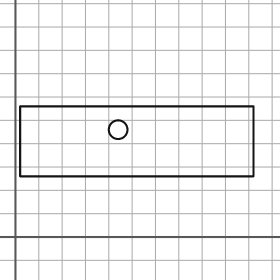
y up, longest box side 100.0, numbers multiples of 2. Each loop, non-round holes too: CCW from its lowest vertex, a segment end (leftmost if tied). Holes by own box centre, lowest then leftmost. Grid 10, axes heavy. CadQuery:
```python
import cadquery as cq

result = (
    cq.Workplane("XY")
    .moveTo(2.0, 26.0)
    .lineTo(102.0, 26.0)
    .lineTo(102.0, 56.0)
    .lineTo(2.0, 56.0)
    .close()
    .moveTo(44.0, 46.0)
    .circle(4.0)
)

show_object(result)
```